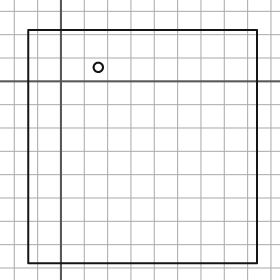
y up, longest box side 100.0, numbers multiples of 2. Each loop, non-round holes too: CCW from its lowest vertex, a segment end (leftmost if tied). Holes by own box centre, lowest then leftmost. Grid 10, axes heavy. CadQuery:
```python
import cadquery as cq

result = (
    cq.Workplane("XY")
    .moveTo(-14.0, -78.0)
    .lineTo(84.0, -78.0)
    .lineTo(84.0, 22.0)
    .lineTo(-14.0, 22.0)
    .close()
    .moveTo(16.0, 6.0)
    .circle(2.0)
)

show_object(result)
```